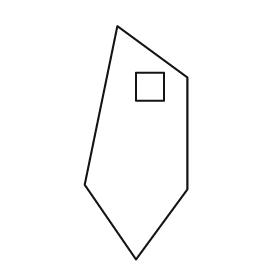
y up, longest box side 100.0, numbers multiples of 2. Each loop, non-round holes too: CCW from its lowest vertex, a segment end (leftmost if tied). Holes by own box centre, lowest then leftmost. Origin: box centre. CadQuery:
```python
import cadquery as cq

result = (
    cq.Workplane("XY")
    .moveTo(0.0, -50.0)
    .lineTo(22.0, -20.0)
    .lineTo(22.0, 28.0)
    .lineTo(-8.0, 50.0)
    .lineTo(-22.0, -18.0)
    .close()
    .moveTo(0.0, 18.0)
    .lineTo(12.0, 18.0)
    .lineTo(12.0, 30.0)
    .lineTo(0.0, 30.0)
    .close()
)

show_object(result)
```